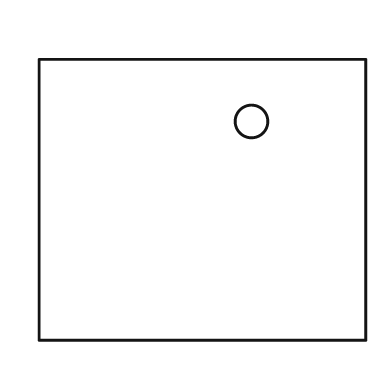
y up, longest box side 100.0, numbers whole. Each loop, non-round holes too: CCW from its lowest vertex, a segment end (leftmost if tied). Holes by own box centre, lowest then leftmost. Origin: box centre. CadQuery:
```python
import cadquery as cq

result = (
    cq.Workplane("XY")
    .moveTo(-50.0, -43.0)
    .lineTo(50.0, -43.0)
    .lineTo(50.0, 43.0)
    .lineTo(-50.0, 43.0)
    .close()
    .moveTo(15.0, 24.0)
    .circle(5.0)
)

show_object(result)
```